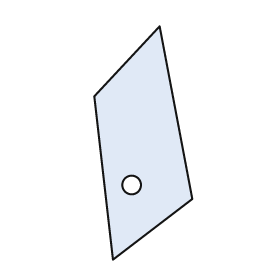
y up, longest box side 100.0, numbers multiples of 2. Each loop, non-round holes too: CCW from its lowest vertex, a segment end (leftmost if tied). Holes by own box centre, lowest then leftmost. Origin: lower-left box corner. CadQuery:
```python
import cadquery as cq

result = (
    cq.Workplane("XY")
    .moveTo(8.0, 0.0)
    .lineTo(42.0, 26.0)
    .lineTo(28.0, 100.0)
    .lineTo(0.0, 70.0)
    .close()
    .moveTo(16.0, 32.0)
    .circle(4.0)
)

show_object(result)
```